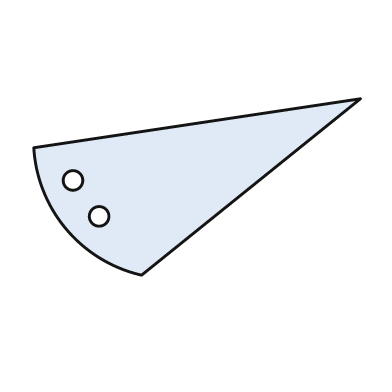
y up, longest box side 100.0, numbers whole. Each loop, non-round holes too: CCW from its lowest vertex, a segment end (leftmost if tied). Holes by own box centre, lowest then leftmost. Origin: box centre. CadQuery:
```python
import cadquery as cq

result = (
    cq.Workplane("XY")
    .moveTo(-17.0, -27.0)
    .lineTo(50.0, 27.0)
    .lineTo(-50.0, 12.0)
    .threePointArc((-40.0, -13.0), (-17.0, -27.0))
    .close()
    .moveTo(-30.0, -9.0)
    .circle(3.0)
    .moveTo(-38.0, 2.0)
    .circle(3.0)
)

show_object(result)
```